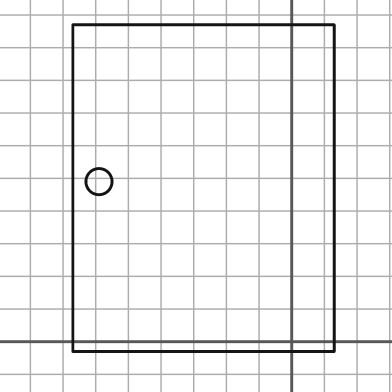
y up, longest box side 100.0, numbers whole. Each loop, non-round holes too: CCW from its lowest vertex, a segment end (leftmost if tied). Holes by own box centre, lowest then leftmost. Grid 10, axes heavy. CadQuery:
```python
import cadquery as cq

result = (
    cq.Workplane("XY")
    .moveTo(-67.0, -3.0)
    .lineTo(13.0, -3.0)
    .lineTo(13.0, 97.0)
    .lineTo(-67.0, 97.0)
    .close()
    .moveTo(-59.0, 49.0)
    .circle(4.0)
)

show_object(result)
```